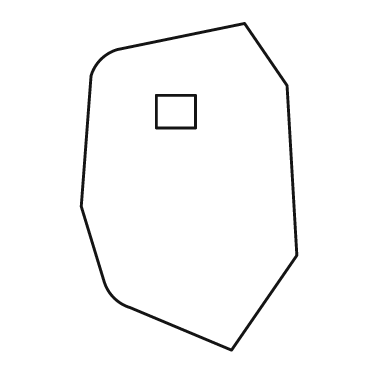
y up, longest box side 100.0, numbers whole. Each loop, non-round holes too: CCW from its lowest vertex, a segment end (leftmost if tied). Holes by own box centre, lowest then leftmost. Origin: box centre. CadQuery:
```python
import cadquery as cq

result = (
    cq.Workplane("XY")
    .moveTo(13.0, -50.0)
    .lineTo(33.0, -21.0)
    .lineTo(30.0, 31.0)
    .lineTo(17.0, 50.0)
    .lineTo(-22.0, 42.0)
    .threePointArc((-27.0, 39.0), (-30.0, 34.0))
    .lineTo(-33.0, -6.0)
    .lineTo(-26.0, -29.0)
    .threePointArc((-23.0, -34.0), (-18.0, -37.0))
    .close()
    .moveTo(-10.0, 18.0)
    .lineTo(2.0, 18.0)
    .lineTo(2.0, 28.0)
    .lineTo(-10.0, 28.0)
    .close()
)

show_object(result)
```